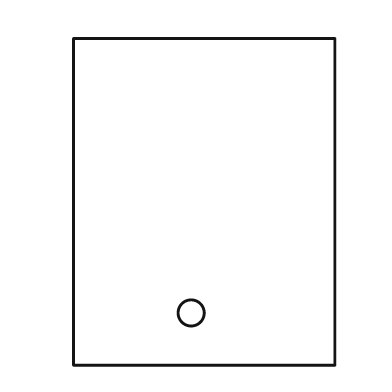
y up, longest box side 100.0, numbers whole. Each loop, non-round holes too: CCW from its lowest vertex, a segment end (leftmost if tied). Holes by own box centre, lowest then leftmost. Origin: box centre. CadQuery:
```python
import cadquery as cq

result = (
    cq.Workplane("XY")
    .moveTo(-40.0, -50.0)
    .lineTo(40.0, -50.0)
    .lineTo(40.0, 50.0)
    .lineTo(-40.0, 50.0)
    .close()
    .moveTo(-4.0, -34.0)
    .circle(4.0)
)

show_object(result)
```